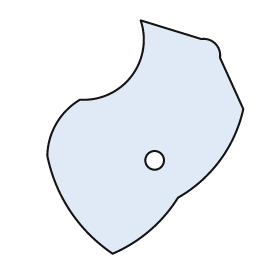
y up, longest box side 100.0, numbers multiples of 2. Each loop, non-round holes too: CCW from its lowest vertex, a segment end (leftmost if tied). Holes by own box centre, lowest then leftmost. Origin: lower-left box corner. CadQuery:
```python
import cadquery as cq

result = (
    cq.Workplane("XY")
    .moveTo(28.0, 0.0)
    .threePointArc((44.0, 10.0), (56.0, 24.0))
    .threePointArc((74.0, 40.0), (84.0, 62.0))
    .lineTo(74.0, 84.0)
    .threePointArc((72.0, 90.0), (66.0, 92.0))
    .lineTo(40.0, 100.0)
    .threePointArc((36.0, 76.0), (14.0, 66.0))
    .threePointArc((4.0, 56.0), (0.0, 42.0))
    .threePointArc((10.0, 18.0), (28.0, 0.0))
    .close()
    .moveTo(46.0, 40.0)
    .circle(4.0)
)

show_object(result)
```